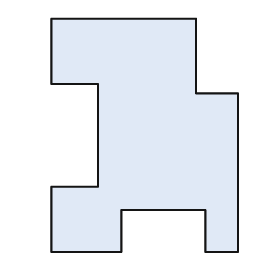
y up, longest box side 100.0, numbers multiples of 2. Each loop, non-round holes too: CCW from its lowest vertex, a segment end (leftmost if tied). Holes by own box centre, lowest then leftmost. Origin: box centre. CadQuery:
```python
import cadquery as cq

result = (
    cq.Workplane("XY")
    .moveTo(-40.0, -50.0)
    .lineTo(-10.0, -50.0)
    .lineTo(-10.0, -32.0)
    .lineTo(26.0, -32.0)
    .lineTo(26.0, -50.0)
    .lineTo(40.0, -50.0)
    .lineTo(40.0, 18.0)
    .lineTo(22.0, 18.0)
    .lineTo(22.0, 50.0)
    .lineTo(-40.0, 50.0)
    .lineTo(-40.0, 22.0)
    .lineTo(-20.0, 22.0)
    .lineTo(-20.0, -22.0)
    .lineTo(-40.0, -22.0)
    .close()
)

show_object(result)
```